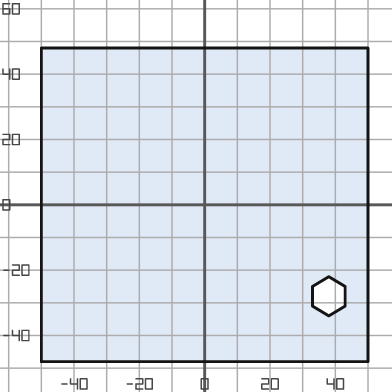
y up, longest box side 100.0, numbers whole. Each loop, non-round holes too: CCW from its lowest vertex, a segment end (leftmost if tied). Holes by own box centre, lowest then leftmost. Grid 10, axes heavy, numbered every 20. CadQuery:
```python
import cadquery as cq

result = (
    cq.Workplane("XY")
    .moveTo(-50.0, -48.0)
    .lineTo(50.0, -48.0)
    .lineTo(50.0, 48.0)
    .lineTo(-50.0, 48.0)
    .close()
    .moveTo(38.0, -34.0)
    .lineTo(43.0, -31.0)
    .lineTo(43.0, -25.0)
    .lineTo(38.0, -22.0)
    .lineTo(33.0, -25.0)
    .lineTo(33.0, -31.0)
    .close()
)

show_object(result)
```